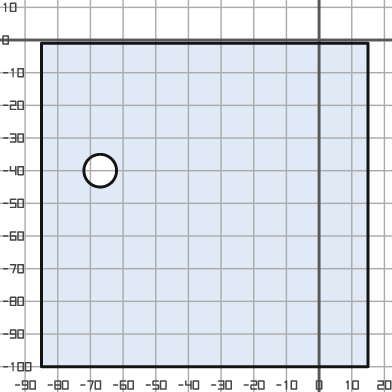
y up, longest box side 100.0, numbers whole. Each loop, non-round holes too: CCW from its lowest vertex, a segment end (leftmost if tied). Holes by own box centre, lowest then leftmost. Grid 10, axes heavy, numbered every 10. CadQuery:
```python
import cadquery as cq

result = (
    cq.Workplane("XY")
    .moveTo(-85.0, -100.0)
    .lineTo(15.0, -100.0)
    .lineTo(15.0, -1.0)
    .lineTo(-85.0, -1.0)
    .close()
    .moveTo(-67.0, -40.0)
    .circle(5.0)
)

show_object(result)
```